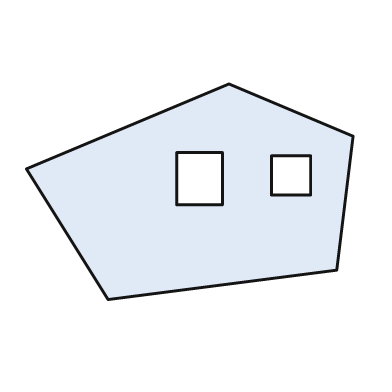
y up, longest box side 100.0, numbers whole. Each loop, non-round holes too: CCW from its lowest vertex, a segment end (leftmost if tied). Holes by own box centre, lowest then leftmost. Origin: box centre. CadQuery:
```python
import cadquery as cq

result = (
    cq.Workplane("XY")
    .moveTo(-25.0, -33.0)
    .lineTo(45.0, -24.0)
    .lineTo(50.0, 17.0)
    .lineTo(12.0, 33.0)
    .lineTo(-50.0, 7.0)
    .close()
    .moveTo(-4.0, -4.0)
    .lineTo(10.0, -4.0)
    .lineTo(10.0, 12.0)
    .lineTo(-4.0, 12.0)
    .close()
    .moveTo(25.0, -1.0)
    .lineTo(37.0, -1.0)
    .lineTo(37.0, 11.0)
    .lineTo(25.0, 11.0)
    .close()
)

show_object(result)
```